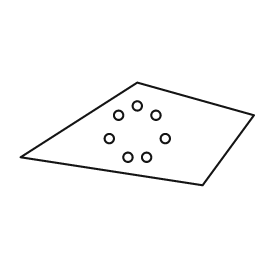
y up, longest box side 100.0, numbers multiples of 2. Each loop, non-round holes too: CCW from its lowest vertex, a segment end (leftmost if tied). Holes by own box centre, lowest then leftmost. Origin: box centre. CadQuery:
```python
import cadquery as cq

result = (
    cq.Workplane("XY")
    .moveTo(28.0, -22.0)
    .lineTo(50.0, 8.0)
    .lineTo(0.0, 22.0)
    .lineTo(-50.0, -10.0)
    .close()
    .moveTo(-4.0, -10.0)
    .circle(2.0)
    .moveTo(4.0, -10.0)
    .circle(2.0)
    .moveTo(-12.0, -2.0)
    .circle(2.0)
    .moveTo(12.0, -2.0)
    .circle(2.0)
    .moveTo(-8.0, 8.0)
    .circle(2.0)
    .moveTo(8.0, 8.0)
    .circle(2.0)
    .moveTo(0.0, 12.0)
    .circle(2.0)
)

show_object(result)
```